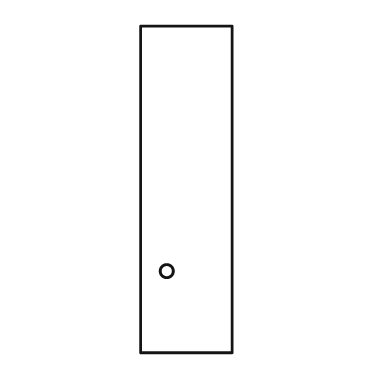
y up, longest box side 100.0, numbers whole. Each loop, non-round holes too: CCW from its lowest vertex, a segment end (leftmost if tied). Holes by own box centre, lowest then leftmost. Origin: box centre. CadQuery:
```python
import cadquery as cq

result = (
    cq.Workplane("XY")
    .moveTo(-14.0, -50.0)
    .lineTo(14.0, -50.0)
    .lineTo(14.0, 50.0)
    .lineTo(-14.0, 50.0)
    .close()
    .moveTo(-6.0, -25.0)
    .circle(2.0)
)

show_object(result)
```